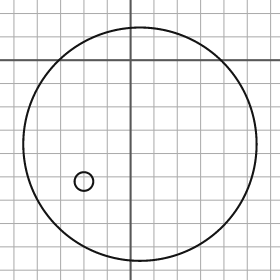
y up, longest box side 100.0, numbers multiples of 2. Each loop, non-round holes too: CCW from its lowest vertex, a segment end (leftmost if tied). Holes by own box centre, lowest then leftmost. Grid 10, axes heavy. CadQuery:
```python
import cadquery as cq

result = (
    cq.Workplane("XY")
    .moveTo(4.0, -36.0)
    .circle(50.0)
    .moveTo(-20.0, -52.0)
    .circle(4.0)
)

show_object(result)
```